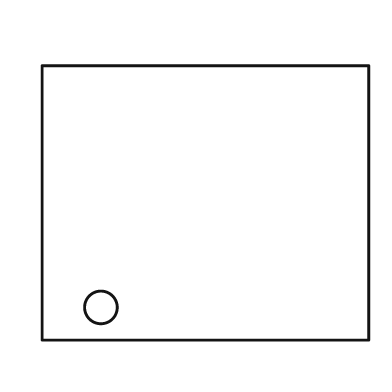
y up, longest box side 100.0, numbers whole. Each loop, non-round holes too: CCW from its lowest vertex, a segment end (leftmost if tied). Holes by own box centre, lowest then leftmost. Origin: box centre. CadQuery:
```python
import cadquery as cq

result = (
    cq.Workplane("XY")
    .moveTo(-50.0, -42.0)
    .lineTo(50.0, -42.0)
    .lineTo(50.0, 42.0)
    .lineTo(-50.0, 42.0)
    .close()
    .moveTo(-32.0, -32.0)
    .circle(5.0)
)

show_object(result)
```